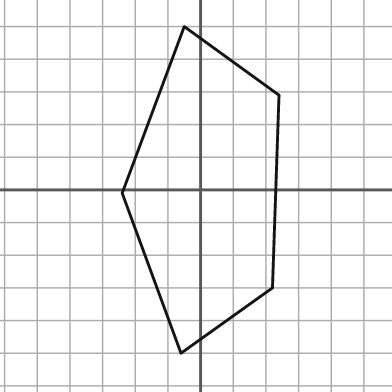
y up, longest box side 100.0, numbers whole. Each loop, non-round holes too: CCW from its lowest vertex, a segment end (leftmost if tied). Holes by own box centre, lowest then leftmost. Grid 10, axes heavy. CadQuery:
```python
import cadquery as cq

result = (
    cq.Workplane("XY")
    .moveTo(-6.0, -50.0)
    .lineTo(22.0, -30.0)
    .lineTo(24.0, 29.0)
    .lineTo(-5.0, 50.0)
    .lineTo(-24.0, -1.0)
    .close()
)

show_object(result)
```